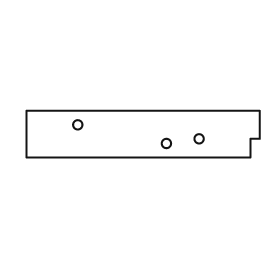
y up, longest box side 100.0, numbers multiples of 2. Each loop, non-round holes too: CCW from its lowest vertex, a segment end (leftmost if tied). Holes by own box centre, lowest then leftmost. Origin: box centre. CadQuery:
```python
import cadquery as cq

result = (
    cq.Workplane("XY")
    .moveTo(-50.0, -10.0)
    .lineTo(46.0, -10.0)
    .lineTo(46.0, -2.0)
    .lineTo(50.0, -2.0)
    .lineTo(50.0, 10.0)
    .lineTo(-50.0, 10.0)
    .close()
    .moveTo(10.0, -4.0)
    .circle(2.0)
    .moveTo(24.0, -2.0)
    .circle(2.0)
    .moveTo(-28.0, 4.0)
    .circle(2.0)
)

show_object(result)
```